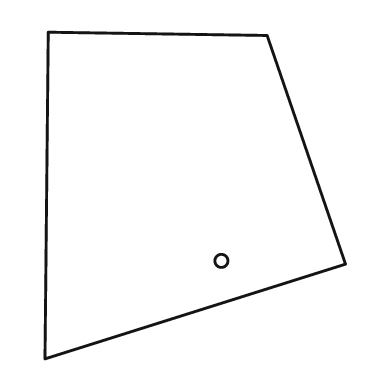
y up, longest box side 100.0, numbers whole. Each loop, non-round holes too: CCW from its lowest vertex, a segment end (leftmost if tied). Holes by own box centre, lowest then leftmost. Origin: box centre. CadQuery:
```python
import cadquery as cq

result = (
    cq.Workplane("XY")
    .moveTo(-46.0, -50.0)
    .lineTo(46.0, -21.0)
    .lineTo(22.0, 49.0)
    .lineTo(-45.0, 50.0)
    .close()
    .moveTo(8.0, -20.0)
    .circle(2.0)
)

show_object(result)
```